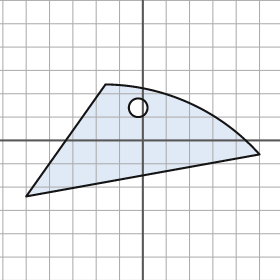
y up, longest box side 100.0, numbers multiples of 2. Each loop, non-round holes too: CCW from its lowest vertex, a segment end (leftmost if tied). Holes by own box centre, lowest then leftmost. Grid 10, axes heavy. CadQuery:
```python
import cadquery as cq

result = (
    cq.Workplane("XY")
    .moveTo(-50.0, -24.0)
    .lineTo(50.0, -6.0)
    .threePointArc((20.0, 16.0), (-16.0, 24.0))
    .close()
    .moveTo(-2.0, 14.0)
    .circle(4.0)
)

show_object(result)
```